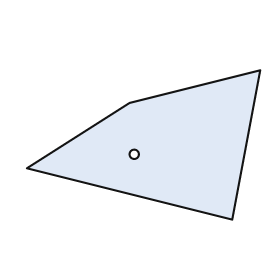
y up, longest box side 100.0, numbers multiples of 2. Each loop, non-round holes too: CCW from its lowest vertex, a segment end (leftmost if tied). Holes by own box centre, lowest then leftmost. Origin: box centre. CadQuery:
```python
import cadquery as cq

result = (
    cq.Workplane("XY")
    .moveTo(38.0, -32.0)
    .lineTo(50.0, 32.0)
    .lineTo(-6.0, 18.0)
    .lineTo(-50.0, -10.0)
    .close()
    .moveTo(-4.0, -4.0)
    .circle(2.0)
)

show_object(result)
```